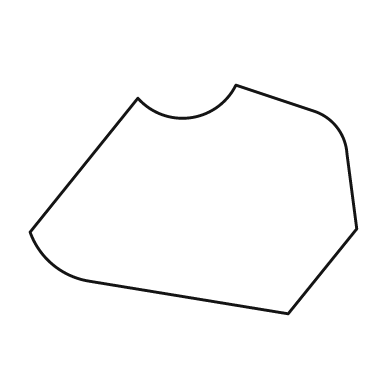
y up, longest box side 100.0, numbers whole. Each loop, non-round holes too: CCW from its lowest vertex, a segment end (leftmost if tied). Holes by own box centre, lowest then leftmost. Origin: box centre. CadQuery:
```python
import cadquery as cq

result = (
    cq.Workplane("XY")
    .moveTo(29.0, -35.0)
    .lineTo(50.0, -9.0)
    .lineTo(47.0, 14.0)
    .threePointArc((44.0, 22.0), (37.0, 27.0))
    .lineTo(13.0, 35.0)
    .threePointArc((-1.0, 25.0), (-17.0, 31.0))
    .lineTo(-50.0, -10.0)
    .threePointArc((-43.0, -20.0), (-32.0, -25.0))
    .close()
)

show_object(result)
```